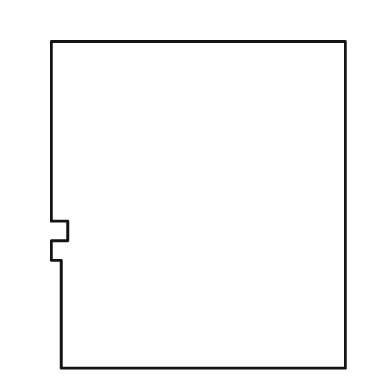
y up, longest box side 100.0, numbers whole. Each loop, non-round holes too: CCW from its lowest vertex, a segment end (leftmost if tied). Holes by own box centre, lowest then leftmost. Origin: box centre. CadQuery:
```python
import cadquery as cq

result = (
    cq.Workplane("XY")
    .moveTo(-42.0, -50.0)
    .lineTo(45.0, -50.0)
    .lineTo(45.0, 50.0)
    .lineTo(-45.0, 50.0)
    .lineTo(-45.0, -5.0)
    .lineTo(-40.0, -5.0)
    .lineTo(-40.0, -11.0)
    .lineTo(-45.0, -11.0)
    .lineTo(-45.0, -17.0)
    .lineTo(-42.0, -17.0)
    .close()
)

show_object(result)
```